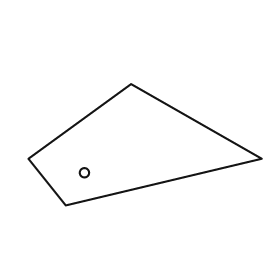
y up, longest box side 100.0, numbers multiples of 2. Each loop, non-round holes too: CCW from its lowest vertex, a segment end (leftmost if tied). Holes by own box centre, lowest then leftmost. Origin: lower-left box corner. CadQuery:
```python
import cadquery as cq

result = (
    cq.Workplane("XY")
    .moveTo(16.0, 0.0)
    .lineTo(100.0, 20.0)
    .lineTo(44.0, 52.0)
    .lineTo(0.0, 20.0)
    .close()
    .moveTo(24.0, 14.0)
    .circle(2.0)
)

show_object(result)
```